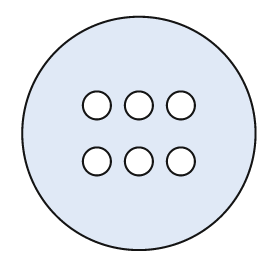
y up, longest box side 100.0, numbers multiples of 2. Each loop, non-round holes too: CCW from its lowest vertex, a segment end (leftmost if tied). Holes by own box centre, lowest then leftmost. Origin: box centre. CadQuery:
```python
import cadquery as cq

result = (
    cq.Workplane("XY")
    .moveTo(0.0, 0.0)
    .circle(50.0)
    .moveTo(-18.0, -12.0)
    .circle(6.0)
    .moveTo(0.0, -12.0)
    .circle(6.0)
    .moveTo(18.0, -12.0)
    .circle(6.0)
    .moveTo(-18.0, 12.0)
    .circle(6.0)
    .moveTo(0.0, 12.0)
    .circle(6.0)
    .moveTo(18.0, 12.0)
    .circle(6.0)
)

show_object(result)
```